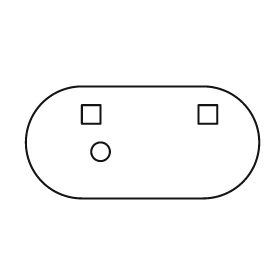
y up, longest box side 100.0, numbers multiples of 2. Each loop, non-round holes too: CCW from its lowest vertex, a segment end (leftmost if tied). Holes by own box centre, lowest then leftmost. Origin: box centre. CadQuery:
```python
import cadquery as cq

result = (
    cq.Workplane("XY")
    .moveTo(-26.0, -24.0)
    .lineTo(26.0, -24.0)
    .threePointArc((50.0, 0.0), (26.0, 24.0))
    .lineTo(-26.0, 24.0)
    .threePointArc((-50.0, 0.0), (-26.0, -24.0))
    .close()
    .moveTo(-18.0, -4.0)
    .circle(4.0)
    .moveTo(-26.0, 8.0)
    .lineTo(-18.0, 8.0)
    .lineTo(-18.0, 16.0)
    .lineTo(-26.0, 16.0)
    .close()
    .moveTo(24.0, 8.0)
    .lineTo(32.0, 8.0)
    .lineTo(32.0, 16.0)
    .lineTo(24.0, 16.0)
    .close()
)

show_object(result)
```